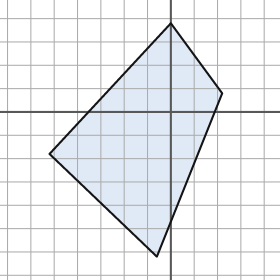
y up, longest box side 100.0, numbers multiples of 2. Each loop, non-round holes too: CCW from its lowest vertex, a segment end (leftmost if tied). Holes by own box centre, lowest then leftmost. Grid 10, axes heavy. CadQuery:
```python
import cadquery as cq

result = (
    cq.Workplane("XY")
    .moveTo(-6.0, -62.0)
    .lineTo(22.0, 8.0)
    .lineTo(0.0, 38.0)
    .lineTo(-52.0, -18.0)
    .close()
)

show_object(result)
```